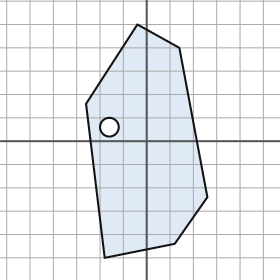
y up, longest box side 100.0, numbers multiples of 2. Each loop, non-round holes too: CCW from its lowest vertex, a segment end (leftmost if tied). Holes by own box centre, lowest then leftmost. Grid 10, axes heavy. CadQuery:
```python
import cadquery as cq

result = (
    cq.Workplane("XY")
    .moveTo(-18.0, -50.0)
    .lineTo(12.0, -44.0)
    .lineTo(26.0, -24.0)
    .lineTo(14.0, 40.0)
    .lineTo(-4.0, 50.0)
    .lineTo(-26.0, 16.0)
    .close()
    .moveTo(-16.0, 6.0)
    .circle(4.0)
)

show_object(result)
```